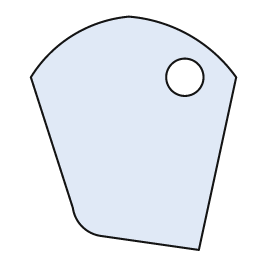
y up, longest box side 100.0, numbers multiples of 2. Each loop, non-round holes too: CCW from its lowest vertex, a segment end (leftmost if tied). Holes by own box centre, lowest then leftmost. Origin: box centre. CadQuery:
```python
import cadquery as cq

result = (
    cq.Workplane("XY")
    .moveTo(28.0, -50.0)
    .lineTo(44.0, 24.0)
    .threePointArc((24.0, 42.0), (-2.0, 50.0))
    .threePointArc((-26.0, 42.0), (-44.0, 24.0))
    .lineTo(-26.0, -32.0)
    .threePointArc((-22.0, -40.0), (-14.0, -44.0))
    .close()
    .moveTo(22.0, 24.0)
    .circle(8.0)
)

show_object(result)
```